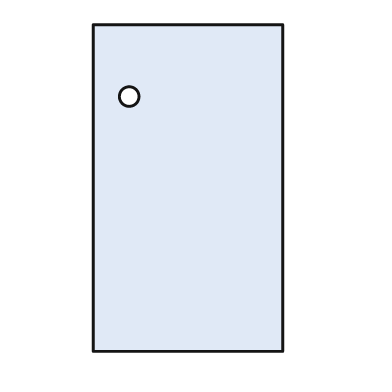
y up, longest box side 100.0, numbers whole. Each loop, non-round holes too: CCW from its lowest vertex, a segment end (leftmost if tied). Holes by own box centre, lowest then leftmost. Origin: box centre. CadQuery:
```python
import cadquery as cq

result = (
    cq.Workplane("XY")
    .moveTo(-29.0, -50.0)
    .lineTo(29.0, -50.0)
    .lineTo(29.0, 50.0)
    .lineTo(-29.0, 50.0)
    .close()
    .moveTo(-18.0, 28.0)
    .circle(3.0)
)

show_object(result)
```